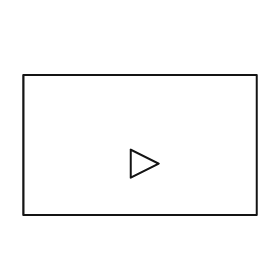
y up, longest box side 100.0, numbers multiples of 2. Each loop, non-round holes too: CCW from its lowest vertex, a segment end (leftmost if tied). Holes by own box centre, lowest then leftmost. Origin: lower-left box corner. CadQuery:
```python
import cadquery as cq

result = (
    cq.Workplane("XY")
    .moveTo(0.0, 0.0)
    .lineTo(100.0, 0.0)
    .lineTo(100.0, 60.0)
    .lineTo(0.0, 60.0)
    .close()
    .moveTo(46.0, 16.0)
    .lineTo(58.0, 22.0)
    .lineTo(46.0, 28.0)
    .close()
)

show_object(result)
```